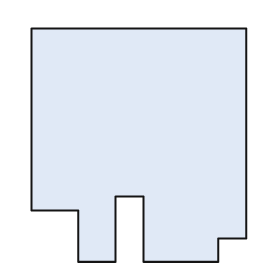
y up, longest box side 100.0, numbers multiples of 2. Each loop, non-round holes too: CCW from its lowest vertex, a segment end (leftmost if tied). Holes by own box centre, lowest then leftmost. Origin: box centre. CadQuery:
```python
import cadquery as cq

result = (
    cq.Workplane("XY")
    .moveTo(-26.0, -50.0)
    .lineTo(-10.0, -50.0)
    .lineTo(-10.0, -22.0)
    .lineTo(2.0, -22.0)
    .lineTo(2.0, -50.0)
    .lineTo(34.0, -50.0)
    .lineTo(34.0, -40.0)
    .lineTo(46.0, -40.0)
    .lineTo(46.0, 50.0)
    .lineTo(-46.0, 50.0)
    .lineTo(-46.0, -28.0)
    .lineTo(-26.0, -28.0)
    .close()
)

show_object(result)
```